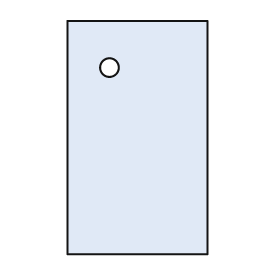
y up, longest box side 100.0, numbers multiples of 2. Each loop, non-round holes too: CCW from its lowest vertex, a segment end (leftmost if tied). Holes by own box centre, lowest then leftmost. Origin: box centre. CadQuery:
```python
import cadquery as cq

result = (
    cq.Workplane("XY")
    .moveTo(-30.0, -50.0)
    .lineTo(30.0, -50.0)
    .lineTo(30.0, 50.0)
    .lineTo(-30.0, 50.0)
    .close()
    .moveTo(-12.0, 30.0)
    .circle(4.0)
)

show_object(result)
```